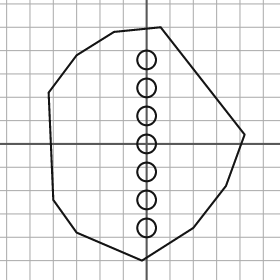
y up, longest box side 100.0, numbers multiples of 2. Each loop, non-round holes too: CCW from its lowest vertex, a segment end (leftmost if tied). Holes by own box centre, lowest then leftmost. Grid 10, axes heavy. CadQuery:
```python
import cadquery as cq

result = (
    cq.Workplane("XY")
    .moveTo(-2.0, -50.0)
    .lineTo(20.0, -36.0)
    .lineTo(34.0, -18.0)
    .lineTo(42.0, 4.0)
    .lineTo(6.0, 50.0)
    .lineTo(-14.0, 48.0)
    .lineTo(-30.0, 38.0)
    .lineTo(-42.0, 22.0)
    .lineTo(-40.0, -24.0)
    .lineTo(-30.0, -38.0)
    .close()
    .moveTo(0.0, -36.0)
    .circle(4.0)
    .moveTo(0.0, -24.0)
    .circle(4.0)
    .moveTo(0.0, -12.0)
    .circle(4.0)
    .moveTo(0.0, 0.0)
    .circle(4.0)
    .moveTo(0.0, 12.0)
    .circle(4.0)
    .moveTo(0.0, 24.0)
    .circle(4.0)
    .moveTo(0.0, 36.0)
    .circle(4.0)
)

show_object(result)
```